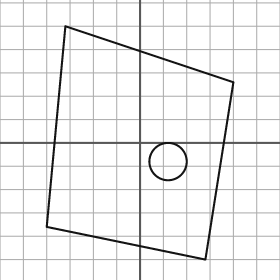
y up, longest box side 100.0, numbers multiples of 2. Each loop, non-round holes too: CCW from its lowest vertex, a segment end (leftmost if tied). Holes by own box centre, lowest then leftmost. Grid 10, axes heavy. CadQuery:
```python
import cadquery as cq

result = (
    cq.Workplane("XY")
    .moveTo(28.0, -50.0)
    .lineTo(40.0, 26.0)
    .lineTo(-32.0, 50.0)
    .lineTo(-40.0, -36.0)
    .close()
    .moveTo(12.0, -8.0)
    .circle(8.0)
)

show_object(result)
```